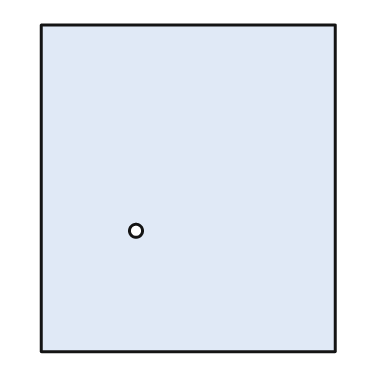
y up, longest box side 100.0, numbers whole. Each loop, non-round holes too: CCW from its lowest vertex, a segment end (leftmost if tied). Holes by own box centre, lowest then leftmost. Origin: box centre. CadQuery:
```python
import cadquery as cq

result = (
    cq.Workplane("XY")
    .moveTo(-45.0, -50.0)
    .lineTo(45.0, -50.0)
    .lineTo(45.0, 50.0)
    .lineTo(-45.0, 50.0)
    .close()
    .moveTo(-16.0, -13.0)
    .circle(2.0)
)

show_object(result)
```